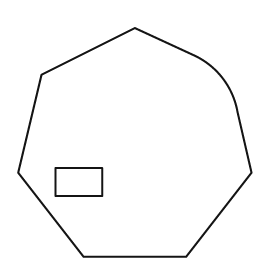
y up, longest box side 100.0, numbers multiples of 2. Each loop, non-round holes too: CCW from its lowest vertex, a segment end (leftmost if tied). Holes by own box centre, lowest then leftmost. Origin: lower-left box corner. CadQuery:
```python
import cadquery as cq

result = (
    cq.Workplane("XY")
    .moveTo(28.0, 0.0)
    .lineTo(72.0, 0.0)
    .lineTo(100.0, 36.0)
    .lineTo(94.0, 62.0)
    .threePointArc((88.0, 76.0), (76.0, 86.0))
    .lineTo(50.0, 98.0)
    .lineTo(10.0, 78.0)
    .lineTo(0.0, 36.0)
    .close()
    .moveTo(16.0, 26.0)
    .lineTo(36.0, 26.0)
    .lineTo(36.0, 38.0)
    .lineTo(16.0, 38.0)
    .close()
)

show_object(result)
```